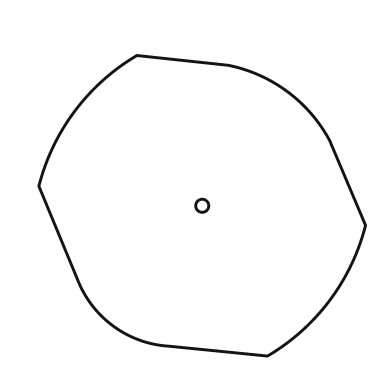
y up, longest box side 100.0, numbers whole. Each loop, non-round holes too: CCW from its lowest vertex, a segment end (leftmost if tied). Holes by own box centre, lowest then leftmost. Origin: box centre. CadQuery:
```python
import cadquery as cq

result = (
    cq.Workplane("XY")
    .moveTo(20.0, -46.0)
    .threePointArc((39.0, -29.0), (50.0, -6.0))
    .lineTo(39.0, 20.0)
    .threePointArc((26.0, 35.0), (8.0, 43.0))
    .lineTo(-20.0, 46.0)
    .threePointArc((-39.0, 29.0), (-50.0, 6.0))
    .lineTo(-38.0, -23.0)
    .threePointArc((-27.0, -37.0), (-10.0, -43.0))
    .close()
    .moveTo(0.0, 0.0)
    .circle(2.0)
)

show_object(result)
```